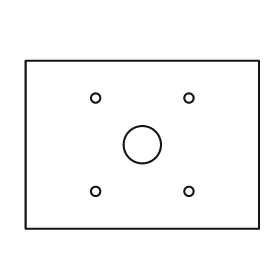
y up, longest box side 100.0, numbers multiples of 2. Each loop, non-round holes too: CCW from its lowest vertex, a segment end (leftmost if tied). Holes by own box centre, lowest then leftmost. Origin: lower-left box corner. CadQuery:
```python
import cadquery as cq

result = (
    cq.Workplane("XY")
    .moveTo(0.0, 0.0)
    .lineTo(100.0, 0.0)
    .lineTo(100.0, 72.0)
    .lineTo(0.0, 72.0)
    .close()
    .moveTo(30.0, 16.0)
    .circle(2.0)
    .moveTo(70.0, 16.0)
    .circle(2.0)
    .moveTo(50.0, 36.0)
    .circle(8.0)
    .moveTo(30.0, 56.0)
    .circle(2.0)
    .moveTo(70.0, 56.0)
    .circle(2.0)
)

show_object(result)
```